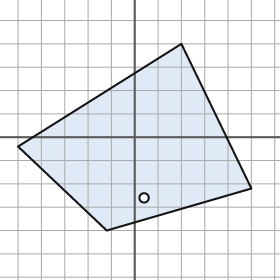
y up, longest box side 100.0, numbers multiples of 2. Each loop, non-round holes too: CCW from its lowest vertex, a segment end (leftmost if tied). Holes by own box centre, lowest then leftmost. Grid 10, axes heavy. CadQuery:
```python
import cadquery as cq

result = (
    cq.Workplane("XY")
    .moveTo(-12.0, -40.0)
    .lineTo(50.0, -22.0)
    .lineTo(20.0, 40.0)
    .lineTo(-50.0, -4.0)
    .close()
    .moveTo(4.0, -26.0)
    .circle(2.0)
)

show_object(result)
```